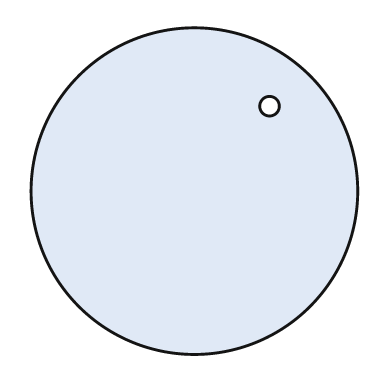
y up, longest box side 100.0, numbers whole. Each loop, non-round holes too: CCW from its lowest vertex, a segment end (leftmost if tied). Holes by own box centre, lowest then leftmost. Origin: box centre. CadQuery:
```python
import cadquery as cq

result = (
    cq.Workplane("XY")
    .moveTo(0.0, 0.0)
    .circle(50.0)
    .moveTo(23.0, 26.0)
    .circle(3.0)
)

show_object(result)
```